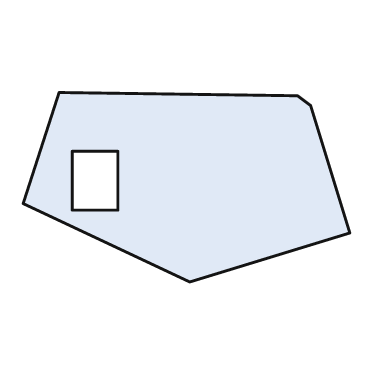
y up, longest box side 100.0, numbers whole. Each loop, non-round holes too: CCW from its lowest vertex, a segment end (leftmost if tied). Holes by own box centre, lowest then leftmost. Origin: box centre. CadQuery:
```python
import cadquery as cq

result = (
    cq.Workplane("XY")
    .moveTo(1.0, -29.0)
    .lineTo(50.0, -14.0)
    .lineTo(38.0, 25.0)
    .lineTo(34.0, 28.0)
    .lineTo(-39.0, 29.0)
    .lineTo(-50.0, -5.0)
    .close()
    .moveTo(-35.0, -7.0)
    .lineTo(-21.0, -7.0)
    .lineTo(-21.0, 11.0)
    .lineTo(-35.0, 11.0)
    .close()
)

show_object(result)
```